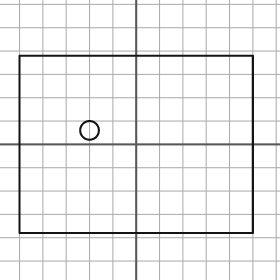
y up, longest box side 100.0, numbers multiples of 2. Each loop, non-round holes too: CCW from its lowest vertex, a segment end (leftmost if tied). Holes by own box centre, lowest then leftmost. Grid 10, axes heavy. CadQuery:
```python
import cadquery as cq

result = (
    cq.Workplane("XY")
    .moveTo(-50.0, -38.0)
    .lineTo(50.0, -38.0)
    .lineTo(50.0, 38.0)
    .lineTo(-50.0, 38.0)
    .close()
    .moveTo(-20.0, 6.0)
    .circle(4.0)
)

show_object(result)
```